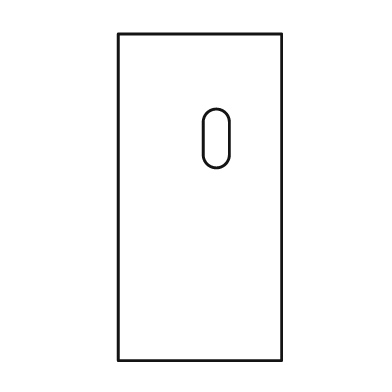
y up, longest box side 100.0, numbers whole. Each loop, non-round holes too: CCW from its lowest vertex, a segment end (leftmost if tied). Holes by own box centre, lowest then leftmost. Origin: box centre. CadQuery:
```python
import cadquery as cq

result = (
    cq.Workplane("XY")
    .moveTo(-25.0, -50.0)
    .lineTo(25.0, -50.0)
    .lineTo(25.0, 50.0)
    .lineTo(-25.0, 50.0)
    .close()
    .moveTo(1.0, 13.0)
    .threePointArc((5.0, 9.0), (9.0, 13.0))
    .lineTo(9.0, 23.0)
    .threePointArc((5.0, 27.0), (1.0, 23.0))
    .close()
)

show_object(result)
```